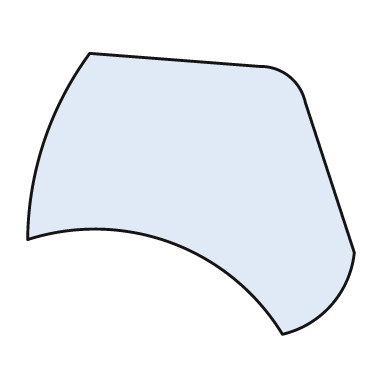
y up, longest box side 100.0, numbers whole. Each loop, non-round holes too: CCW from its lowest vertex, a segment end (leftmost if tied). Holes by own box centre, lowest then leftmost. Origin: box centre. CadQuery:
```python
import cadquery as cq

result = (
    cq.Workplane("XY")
    .moveTo(28.0, -43.0)
    .threePointArc((43.0, -34.0), (50.0, -18.0))
    .lineTo(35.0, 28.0)
    .threePointArc((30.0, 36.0), (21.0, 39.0))
    .lineTo(-31.0, 43.0)
    .threePointArc((-45.0, 16.0), (-50.0, -14.0))
    .threePointArc((-6.0, -15.0), (28.0, -43.0))
    .close()
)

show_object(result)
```